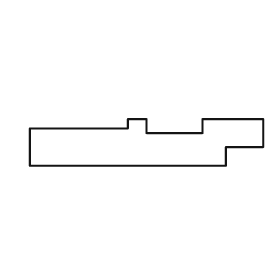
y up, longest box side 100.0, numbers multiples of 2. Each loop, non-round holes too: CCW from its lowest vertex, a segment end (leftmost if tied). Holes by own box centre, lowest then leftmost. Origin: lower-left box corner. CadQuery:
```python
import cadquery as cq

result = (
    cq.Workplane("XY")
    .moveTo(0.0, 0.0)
    .lineTo(84.0, 0.0)
    .lineTo(84.0, 8.0)
    .lineTo(100.0, 8.0)
    .lineTo(100.0, 20.0)
    .lineTo(74.0, 20.0)
    .lineTo(74.0, 14.0)
    .lineTo(50.0, 14.0)
    .lineTo(50.0, 20.0)
    .lineTo(42.0, 20.0)
    .lineTo(42.0, 16.0)
    .lineTo(0.0, 16.0)
    .close()
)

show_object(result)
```